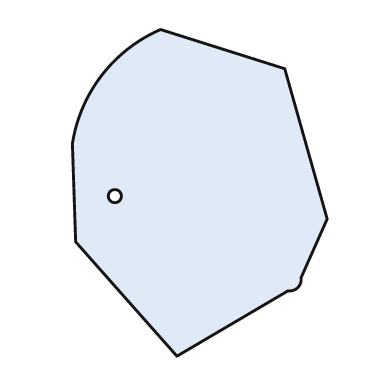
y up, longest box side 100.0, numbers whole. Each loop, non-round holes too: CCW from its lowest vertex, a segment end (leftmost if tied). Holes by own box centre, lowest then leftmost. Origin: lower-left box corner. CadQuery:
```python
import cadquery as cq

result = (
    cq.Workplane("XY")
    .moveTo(32.0, 0.0)
    .lineTo(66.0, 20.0)
    .threePointArc((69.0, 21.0), (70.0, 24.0))
    .lineTo(78.0, 42.0)
    .lineTo(65.0, 88.0)
    .lineTo(27.0, 100.0)
    .threePointArc((9.0, 86.0), (0.0, 65.0))
    .lineTo(1.0, 35.0)
    .close()
    .moveTo(13.0, 49.0)
    .circle(2.0)
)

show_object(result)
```